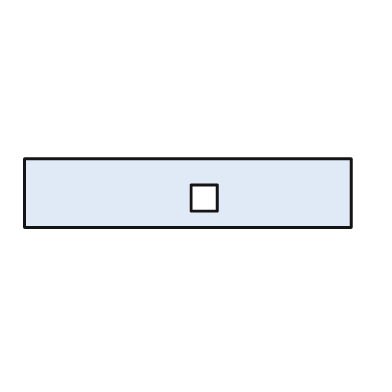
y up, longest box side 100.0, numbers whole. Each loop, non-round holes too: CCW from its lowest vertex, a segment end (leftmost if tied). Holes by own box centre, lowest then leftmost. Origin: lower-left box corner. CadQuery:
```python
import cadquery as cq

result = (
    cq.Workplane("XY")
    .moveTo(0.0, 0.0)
    .lineTo(100.0, 0.0)
    .lineTo(100.0, 21.0)
    .lineTo(0.0, 21.0)
    .close()
    .moveTo(51.0, 5.0)
    .lineTo(59.0, 5.0)
    .lineTo(59.0, 13.0)
    .lineTo(51.0, 13.0)
    .close()
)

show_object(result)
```